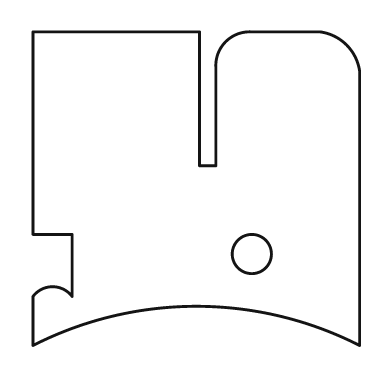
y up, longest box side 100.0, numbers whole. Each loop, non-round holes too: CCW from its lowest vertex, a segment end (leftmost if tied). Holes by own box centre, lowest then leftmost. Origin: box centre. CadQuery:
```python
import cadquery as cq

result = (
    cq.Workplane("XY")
    .moveTo(-50.0, -48.0)
    .threePointArc((0.0, -36.0), (50.0, -48.0))
    .lineTo(50.0, 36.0)
    .threePointArc((46.0, 44.0), (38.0, 48.0))
    .lineTo(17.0, 48.0)
    .threePointArc((9.0, 45.0), (6.0, 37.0))
    .lineTo(6.0, 7.0)
    .lineTo(1.0, 7.0)
    .lineTo(1.0, 48.0)
    .lineTo(-50.0, 48.0)
    .lineTo(-50.0, -14.0)
    .lineTo(-38.0, -14.0)
    .lineTo(-38.0, -33.0)
    .threePointArc((-44.0, -30.0), (-50.0, -33.0))
    .close()
    .moveTo(17.0, -20.0)
    .circle(6.0)
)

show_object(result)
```